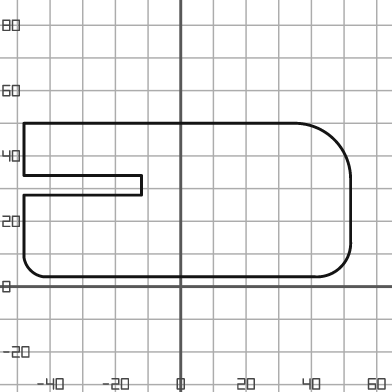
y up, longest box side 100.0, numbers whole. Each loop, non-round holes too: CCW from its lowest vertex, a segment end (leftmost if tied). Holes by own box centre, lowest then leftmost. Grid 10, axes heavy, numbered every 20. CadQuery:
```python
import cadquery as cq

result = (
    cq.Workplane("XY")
    .moveTo(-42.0, 3.0)
    .lineTo(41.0, 3.0)
    .threePointArc((49.0, 6.0), (52.0, 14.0))
    .lineTo(52.0, 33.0)
    .threePointArc((47.0, 45.0), (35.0, 50.0))
    .lineTo(-48.0, 50.0)
    .lineTo(-48.0, 34.0)
    .lineTo(-12.0, 34.0)
    .lineTo(-12.0, 28.0)
    .lineTo(-48.0, 28.0)
    .lineTo(-48.0, 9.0)
    .threePointArc((-46.0, 5.0), (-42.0, 3.0))
    .close()
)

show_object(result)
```